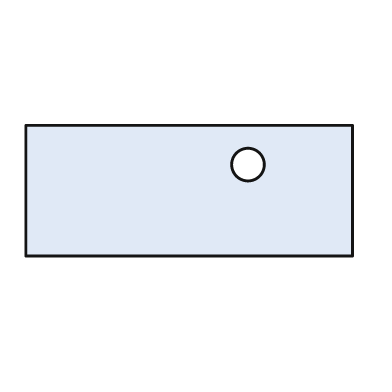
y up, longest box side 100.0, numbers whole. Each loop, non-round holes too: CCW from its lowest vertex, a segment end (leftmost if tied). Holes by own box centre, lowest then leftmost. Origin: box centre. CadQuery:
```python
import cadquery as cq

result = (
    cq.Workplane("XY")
    .moveTo(-50.0, -20.0)
    .lineTo(50.0, -20.0)
    .lineTo(50.0, 20.0)
    .lineTo(-50.0, 20.0)
    .close()
    .moveTo(18.0, 8.0)
    .circle(5.0)
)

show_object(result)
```